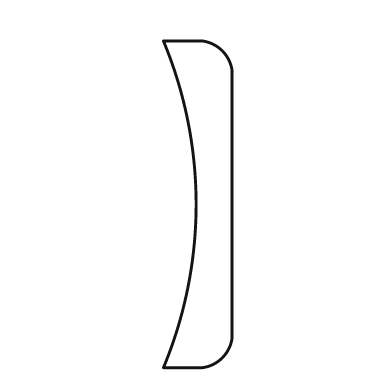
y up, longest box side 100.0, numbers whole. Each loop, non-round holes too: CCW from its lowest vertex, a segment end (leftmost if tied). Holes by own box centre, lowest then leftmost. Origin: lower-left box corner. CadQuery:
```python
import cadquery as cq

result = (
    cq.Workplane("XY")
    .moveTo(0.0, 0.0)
    .lineTo(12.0, 0.0)
    .threePointArc((18.0, 3.0), (21.0, 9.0))
    .lineTo(21.0, 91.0)
    .threePointArc((18.0, 97.0), (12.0, 100.0))
    .lineTo(0.0, 100.0)
    .threePointArc((10.0, 50.0), (0.0, 0.0))
    .close()
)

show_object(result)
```